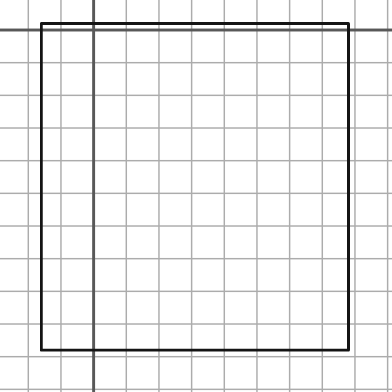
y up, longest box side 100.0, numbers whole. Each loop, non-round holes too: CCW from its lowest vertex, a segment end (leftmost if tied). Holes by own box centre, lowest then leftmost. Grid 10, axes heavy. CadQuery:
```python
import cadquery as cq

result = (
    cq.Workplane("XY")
    .moveTo(-16.0, -98.0)
    .lineTo(78.0, -98.0)
    .lineTo(78.0, 2.0)
    .lineTo(-16.0, 2.0)
    .close()
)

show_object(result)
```